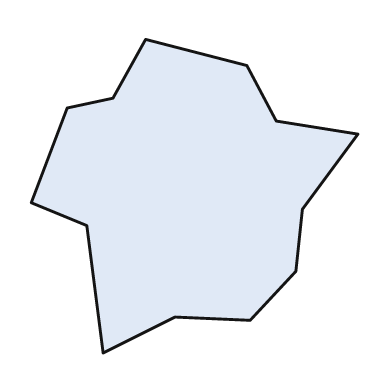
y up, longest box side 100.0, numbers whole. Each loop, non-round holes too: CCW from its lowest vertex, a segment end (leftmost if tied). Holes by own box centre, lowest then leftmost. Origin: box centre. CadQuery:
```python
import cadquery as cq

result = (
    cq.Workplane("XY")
    .moveTo(-28.0, -48.0)
    .lineTo(-6.0, -37.0)
    .lineTo(17.0, -38.0)
    .lineTo(31.0, -23.0)
    .lineTo(33.0, -4.0)
    .lineTo(50.0, 19.0)
    .lineTo(25.0, 23.0)
    .lineTo(16.0, 40.0)
    .lineTo(-15.0, 48.0)
    .lineTo(-25.0, 30.0)
    .lineTo(-39.0, 27.0)
    .lineTo(-50.0, -2.0)
    .lineTo(-33.0, -9.0)
    .close()
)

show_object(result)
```